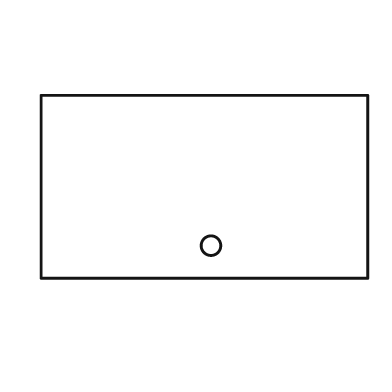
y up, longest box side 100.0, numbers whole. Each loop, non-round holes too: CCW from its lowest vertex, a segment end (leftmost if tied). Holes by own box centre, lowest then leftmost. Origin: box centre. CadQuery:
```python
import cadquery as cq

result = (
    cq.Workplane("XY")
    .moveTo(-50.0, -28.0)
    .lineTo(50.0, -28.0)
    .lineTo(50.0, 28.0)
    .lineTo(-50.0, 28.0)
    .close()
    .moveTo(2.0, -18.0)
    .circle(3.0)
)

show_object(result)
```